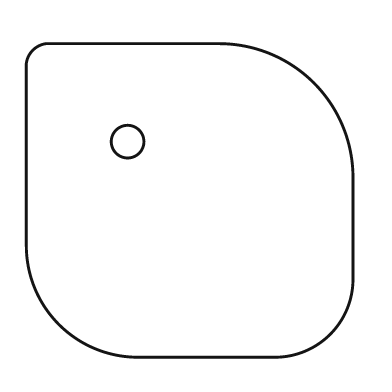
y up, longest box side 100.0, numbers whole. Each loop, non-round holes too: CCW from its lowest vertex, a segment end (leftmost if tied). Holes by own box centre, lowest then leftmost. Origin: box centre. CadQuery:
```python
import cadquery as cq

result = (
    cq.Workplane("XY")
    .moveTo(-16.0, -48.0)
    .lineTo(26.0, -48.0)
    .threePointArc((43.0, -41.0), (50.0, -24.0))
    .lineTo(50.0, 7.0)
    .threePointArc((38.0, 36.0), (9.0, 48.0))
    .lineTo(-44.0, 48.0)
    .threePointArc((-48.0, 46.0), (-50.0, 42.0))
    .lineTo(-50.0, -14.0)
    .threePointArc((-40.0, -38.0), (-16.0, -48.0))
    .close()
    .moveTo(-19.0, 18.0)
    .circle(5.0)
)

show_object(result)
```